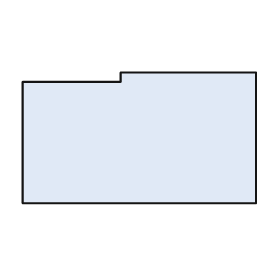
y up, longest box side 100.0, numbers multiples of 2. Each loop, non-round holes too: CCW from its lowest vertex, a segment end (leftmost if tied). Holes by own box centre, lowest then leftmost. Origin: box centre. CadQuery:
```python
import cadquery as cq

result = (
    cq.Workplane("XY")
    .moveTo(-50.0, -28.0)
    .lineTo(50.0, -28.0)
    .lineTo(50.0, 28.0)
    .lineTo(-8.0, 28.0)
    .lineTo(-8.0, 24.0)
    .lineTo(-50.0, 24.0)
    .close()
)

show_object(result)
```